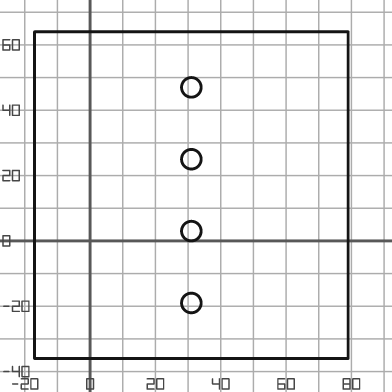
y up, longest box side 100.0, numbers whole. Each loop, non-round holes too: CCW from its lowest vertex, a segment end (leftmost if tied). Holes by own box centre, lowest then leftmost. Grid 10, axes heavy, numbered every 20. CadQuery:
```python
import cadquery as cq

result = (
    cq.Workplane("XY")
    .moveTo(-17.0, -36.0)
    .lineTo(79.0, -36.0)
    .lineTo(79.0, 64.0)
    .lineTo(-17.0, 64.0)
    .close()
    .moveTo(31.0, -19.0)
    .circle(3.0)
    .moveTo(31.0, 3.0)
    .circle(3.0)
    .moveTo(31.0, 25.0)
    .circle(3.0)
    .moveTo(31.0, 47.0)
    .circle(3.0)
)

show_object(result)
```